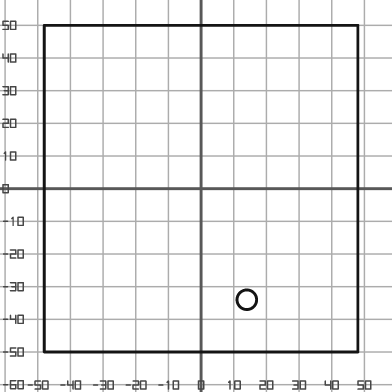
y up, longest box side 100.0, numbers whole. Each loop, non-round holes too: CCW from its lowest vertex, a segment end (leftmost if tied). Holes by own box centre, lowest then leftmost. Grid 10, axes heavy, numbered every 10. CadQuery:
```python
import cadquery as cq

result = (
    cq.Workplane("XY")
    .moveTo(-48.0, -50.0)
    .lineTo(48.0, -50.0)
    .lineTo(48.0, 50.0)
    .lineTo(-48.0, 50.0)
    .close()
    .moveTo(14.0, -34.0)
    .circle(3.0)
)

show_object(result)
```